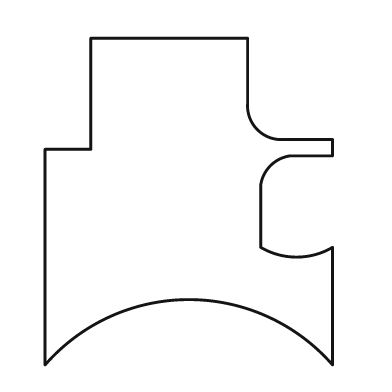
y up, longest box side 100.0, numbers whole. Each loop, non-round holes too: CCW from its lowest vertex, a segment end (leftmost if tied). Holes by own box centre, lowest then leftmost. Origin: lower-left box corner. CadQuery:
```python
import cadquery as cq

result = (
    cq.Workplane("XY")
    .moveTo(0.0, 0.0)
    .threePointArc((44.0, 20.0), (88.0, 0.0))
    .lineTo(88.0, 36.0)
    .threePointArc((77.0, 33.0), (66.0, 36.0))
    .lineTo(66.0, 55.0)
    .threePointArc((69.0, 61.0), (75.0, 64.0))
    .lineTo(88.0, 64.0)
    .lineTo(88.0, 69.0)
    .lineTo(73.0, 69.0)
    .threePointArc((65.0, 72.0), (62.0, 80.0))
    .lineTo(62.0, 100.0)
    .lineTo(14.0, 100.0)
    .lineTo(14.0, 66.0)
    .lineTo(0.0, 66.0)
    .close()
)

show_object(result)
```